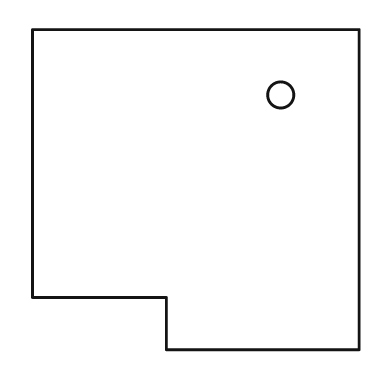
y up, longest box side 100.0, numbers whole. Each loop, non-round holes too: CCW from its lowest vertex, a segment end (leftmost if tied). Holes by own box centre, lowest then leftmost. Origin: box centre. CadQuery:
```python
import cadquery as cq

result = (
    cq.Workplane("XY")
    .moveTo(-9.0, -49.0)
    .lineTo(50.0, -49.0)
    .lineTo(50.0, 49.0)
    .lineTo(-50.0, 49.0)
    .lineTo(-50.0, -33.0)
    .lineTo(-9.0, -33.0)
    .close()
    .moveTo(26.0, 29.0)
    .circle(4.0)
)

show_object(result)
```